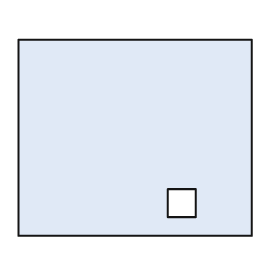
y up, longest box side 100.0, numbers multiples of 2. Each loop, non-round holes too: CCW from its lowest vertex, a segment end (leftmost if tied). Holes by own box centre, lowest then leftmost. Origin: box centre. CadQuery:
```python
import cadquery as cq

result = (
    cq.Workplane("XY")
    .moveTo(-50.0, -42.0)
    .lineTo(50.0, -42.0)
    .lineTo(50.0, 42.0)
    .lineTo(-50.0, 42.0)
    .close()
    .moveTo(14.0, -34.0)
    .lineTo(26.0, -34.0)
    .lineTo(26.0, -22.0)
    .lineTo(14.0, -22.0)
    .close()
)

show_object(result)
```